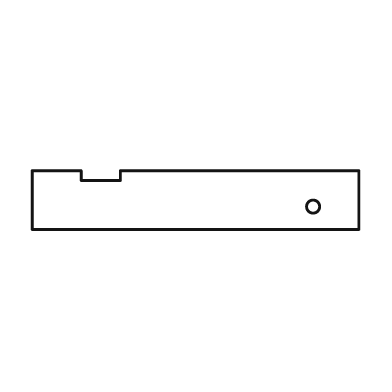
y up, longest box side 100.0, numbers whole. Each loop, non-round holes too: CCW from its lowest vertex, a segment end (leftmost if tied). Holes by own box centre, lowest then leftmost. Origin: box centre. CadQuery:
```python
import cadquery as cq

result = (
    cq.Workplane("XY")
    .moveTo(-50.0, -9.0)
    .lineTo(50.0, -9.0)
    .lineTo(50.0, 9.0)
    .lineTo(-23.0, 9.0)
    .lineTo(-23.0, 6.0)
    .lineTo(-35.0, 6.0)
    .lineTo(-35.0, 9.0)
    .lineTo(-50.0, 9.0)
    .close()
    .moveTo(36.0, -2.0)
    .circle(2.0)
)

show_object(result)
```